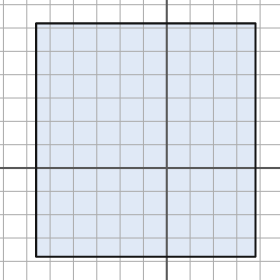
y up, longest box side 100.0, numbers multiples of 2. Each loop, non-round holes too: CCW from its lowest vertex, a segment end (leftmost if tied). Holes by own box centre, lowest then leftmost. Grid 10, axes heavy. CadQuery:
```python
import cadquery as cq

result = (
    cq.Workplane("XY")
    .moveTo(-56.0, -38.0)
    .lineTo(38.0, -38.0)
    .lineTo(38.0, 62.0)
    .lineTo(-56.0, 62.0)
    .close()
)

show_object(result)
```